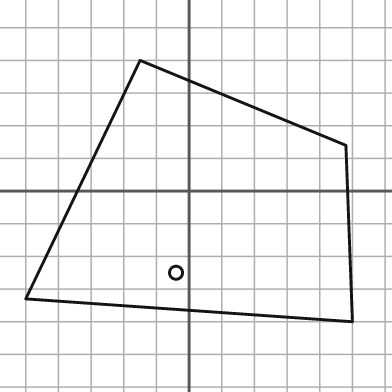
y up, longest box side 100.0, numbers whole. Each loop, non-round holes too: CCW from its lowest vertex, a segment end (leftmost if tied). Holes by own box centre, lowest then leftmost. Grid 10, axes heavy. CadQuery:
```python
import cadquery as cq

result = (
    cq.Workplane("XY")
    .moveTo(50.0, -40.0)
    .lineTo(48.0, 14.0)
    .lineTo(-15.0, 40.0)
    .lineTo(-50.0, -33.0)
    .close()
    .moveTo(-4.0, -25.0)
    .circle(2.0)
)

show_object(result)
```